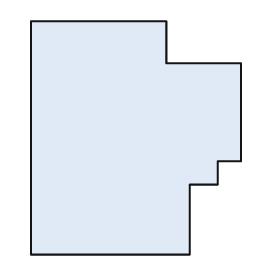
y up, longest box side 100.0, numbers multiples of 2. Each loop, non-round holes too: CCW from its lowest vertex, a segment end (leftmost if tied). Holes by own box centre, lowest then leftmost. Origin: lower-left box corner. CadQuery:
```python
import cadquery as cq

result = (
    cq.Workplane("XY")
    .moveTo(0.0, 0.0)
    .lineTo(68.0, 0.0)
    .lineTo(68.0, 30.0)
    .lineTo(80.0, 30.0)
    .lineTo(80.0, 40.0)
    .lineTo(90.0, 40.0)
    .lineTo(90.0, 82.0)
    .lineTo(58.0, 82.0)
    .lineTo(58.0, 100.0)
    .lineTo(0.0, 100.0)
    .close()
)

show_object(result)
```